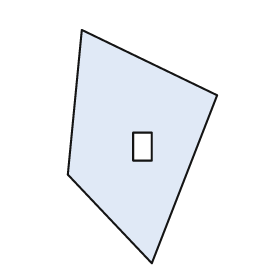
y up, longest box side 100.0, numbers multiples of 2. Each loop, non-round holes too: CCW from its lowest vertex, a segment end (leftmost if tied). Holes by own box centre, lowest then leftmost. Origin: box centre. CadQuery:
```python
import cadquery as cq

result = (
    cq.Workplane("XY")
    .moveTo(4.0, -50.0)
    .lineTo(32.0, 22.0)
    .lineTo(-26.0, 50.0)
    .lineTo(-32.0, -12.0)
    .close()
    .moveTo(-4.0, -6.0)
    .lineTo(4.0, -6.0)
    .lineTo(4.0, 6.0)
    .lineTo(-4.0, 6.0)
    .close()
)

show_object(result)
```